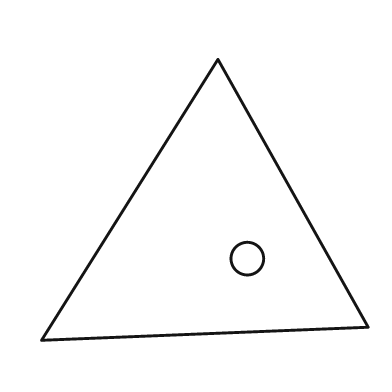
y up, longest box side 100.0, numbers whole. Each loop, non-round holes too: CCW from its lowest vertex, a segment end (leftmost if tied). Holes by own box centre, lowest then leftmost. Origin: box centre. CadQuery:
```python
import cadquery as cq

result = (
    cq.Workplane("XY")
    .moveTo(-50.0, -43.0)
    .lineTo(50.0, -39.0)
    .lineTo(4.0, 43.0)
    .close()
    .moveTo(13.0, -18.0)
    .circle(5.0)
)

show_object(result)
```